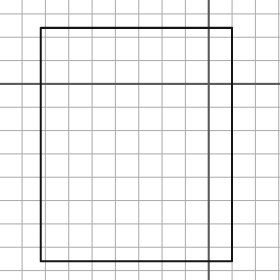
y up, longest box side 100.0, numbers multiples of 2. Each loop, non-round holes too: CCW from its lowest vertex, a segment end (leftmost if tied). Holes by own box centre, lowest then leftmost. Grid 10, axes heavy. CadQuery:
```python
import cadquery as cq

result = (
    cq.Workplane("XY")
    .moveTo(-72.0, -76.0)
    .lineTo(10.0, -76.0)
    .lineTo(10.0, 24.0)
    .lineTo(-72.0, 24.0)
    .close()
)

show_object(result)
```